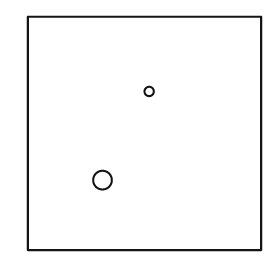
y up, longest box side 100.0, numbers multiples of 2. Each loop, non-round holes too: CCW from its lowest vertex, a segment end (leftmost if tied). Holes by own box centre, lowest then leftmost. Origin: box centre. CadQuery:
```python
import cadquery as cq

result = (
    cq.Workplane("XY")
    .moveTo(-50.0, -50.0)
    .lineTo(50.0, -50.0)
    .lineTo(50.0, 50.0)
    .lineTo(-50.0, 50.0)
    .close()
    .moveTo(-18.0, -20.0)
    .circle(4.0)
    .moveTo(2.0, 18.0)
    .circle(2.0)
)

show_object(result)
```